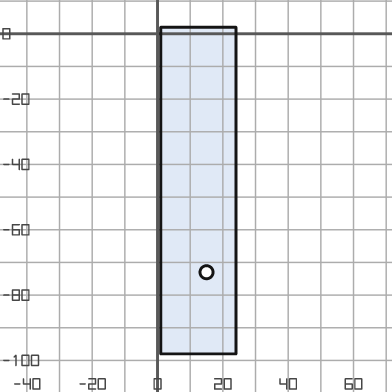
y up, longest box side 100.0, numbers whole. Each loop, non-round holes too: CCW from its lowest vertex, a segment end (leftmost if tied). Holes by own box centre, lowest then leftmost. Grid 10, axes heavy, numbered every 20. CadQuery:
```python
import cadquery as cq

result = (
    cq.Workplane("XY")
    .moveTo(1.0, -98.0)
    .lineTo(24.0, -98.0)
    .lineTo(24.0, 2.0)
    .lineTo(1.0, 2.0)
    .close()
    .moveTo(15.0, -73.0)
    .circle(2.0)
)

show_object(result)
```